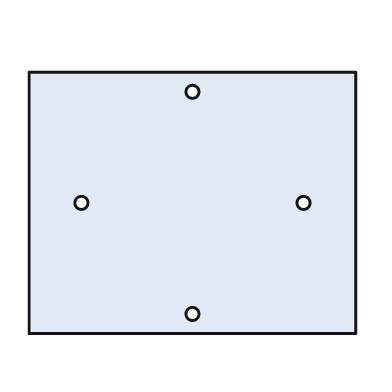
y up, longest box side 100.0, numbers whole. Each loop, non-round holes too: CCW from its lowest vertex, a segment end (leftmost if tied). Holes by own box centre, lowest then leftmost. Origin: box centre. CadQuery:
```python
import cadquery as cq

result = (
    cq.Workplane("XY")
    .moveTo(-50.0, -40.0)
    .lineTo(50.0, -40.0)
    .lineTo(50.0, 40.0)
    .lineTo(-50.0, 40.0)
    .close()
    .moveTo(0.0, -34.0)
    .circle(2.0)
    .moveTo(-34.0, 0.0)
    .circle(2.0)
    .moveTo(34.0, 0.0)
    .circle(2.0)
    .moveTo(0.0, 34.0)
    .circle(2.0)
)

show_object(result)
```